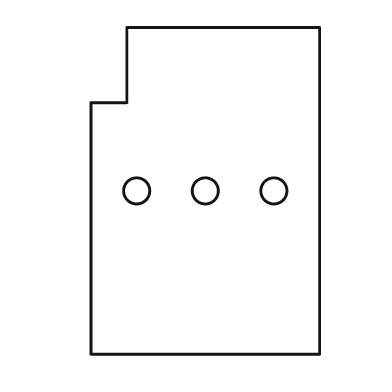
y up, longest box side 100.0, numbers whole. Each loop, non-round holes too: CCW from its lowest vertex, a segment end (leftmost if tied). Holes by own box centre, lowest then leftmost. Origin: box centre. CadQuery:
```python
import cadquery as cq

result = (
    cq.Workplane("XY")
    .moveTo(-35.0, -50.0)
    .lineTo(35.0, -50.0)
    .lineTo(35.0, 50.0)
    .lineTo(-24.0, 50.0)
    .lineTo(-24.0, 27.0)
    .lineTo(-35.0, 27.0)
    .close()
    .moveTo(-21.0, 0.0)
    .circle(4.0)
    .moveTo(0.0, 0.0)
    .circle(4.0)
    .moveTo(21.0, 0.0)
    .circle(4.0)
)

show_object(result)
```